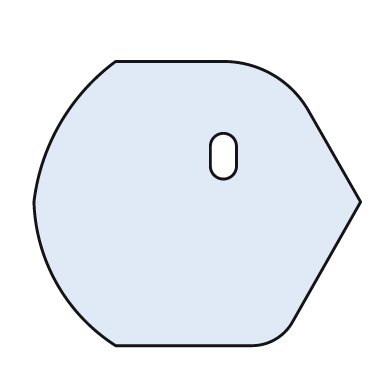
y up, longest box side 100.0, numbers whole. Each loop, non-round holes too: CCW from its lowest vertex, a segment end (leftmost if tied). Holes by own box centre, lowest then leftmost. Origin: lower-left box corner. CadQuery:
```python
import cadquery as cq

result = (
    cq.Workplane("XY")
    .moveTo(25.0, 0.0)
    .lineTo(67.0, 0.0)
    .threePointArc((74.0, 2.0), (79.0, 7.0))
    .lineTo(100.0, 44.0)
    .lineTo(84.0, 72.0)
    .threePointArc((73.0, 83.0), (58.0, 87.0))
    .lineTo(25.0, 87.0)
    .threePointArc((8.0, 68.0), (0.0, 44.0))
    .threePointArc((7.0, 19.0), (25.0, 0.0))
    .close()
    .moveTo(54.0, 55.0)
    .threePointArc((58.0, 51.0), (62.0, 55.0))
    .lineTo(62.0, 61.0)
    .threePointArc((58.0, 65.0), (54.0, 61.0))
    .close()
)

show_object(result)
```